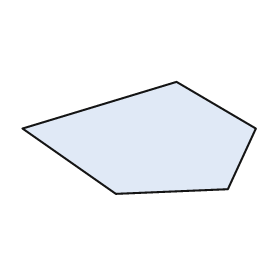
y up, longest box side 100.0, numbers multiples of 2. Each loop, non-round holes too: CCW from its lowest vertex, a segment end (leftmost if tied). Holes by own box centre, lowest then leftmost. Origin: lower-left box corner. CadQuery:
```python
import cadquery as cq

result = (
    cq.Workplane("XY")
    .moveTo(40.0, 0.0)
    .lineTo(88.0, 2.0)
    .lineTo(100.0, 28.0)
    .lineTo(66.0, 48.0)
    .lineTo(0.0, 28.0)
    .close()
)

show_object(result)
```